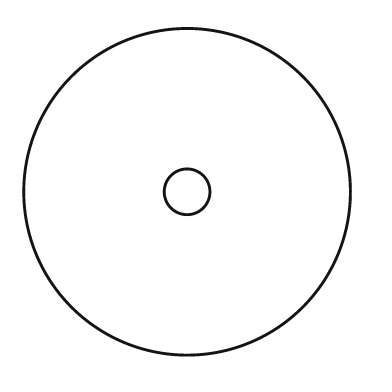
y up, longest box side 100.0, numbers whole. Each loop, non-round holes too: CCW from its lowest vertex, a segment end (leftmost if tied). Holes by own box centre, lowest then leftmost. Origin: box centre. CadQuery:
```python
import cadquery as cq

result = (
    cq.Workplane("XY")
    .moveTo(0.0, 0.0)
    .circle(50.0)
    .moveTo(0.0, 0.0)
    .circle(7.0)
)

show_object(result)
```